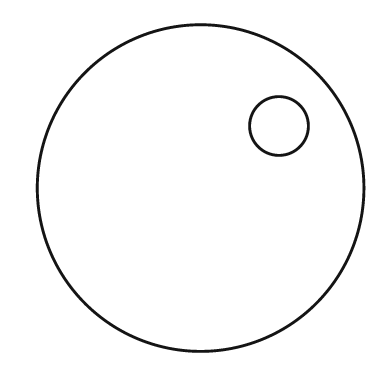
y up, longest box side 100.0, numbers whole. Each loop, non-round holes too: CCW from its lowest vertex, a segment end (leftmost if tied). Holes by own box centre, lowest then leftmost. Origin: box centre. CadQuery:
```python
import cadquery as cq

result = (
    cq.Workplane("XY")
    .moveTo(0.0, 0.0)
    .circle(50.0)
    .moveTo(24.0, 19.0)
    .circle(9.0)
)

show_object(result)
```